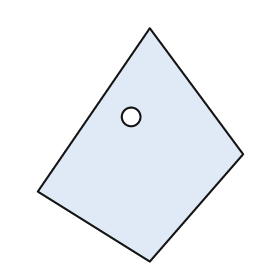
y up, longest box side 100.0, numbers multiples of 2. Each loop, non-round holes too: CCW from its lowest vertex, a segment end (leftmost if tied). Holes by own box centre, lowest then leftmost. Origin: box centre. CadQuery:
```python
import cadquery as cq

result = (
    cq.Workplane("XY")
    .moveTo(4.0, -50.0)
    .lineTo(44.0, -4.0)
    .lineTo(4.0, 50.0)
    .lineTo(-44.0, -20.0)
    .close()
    .moveTo(-4.0, 12.0)
    .circle(4.0)
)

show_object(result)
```